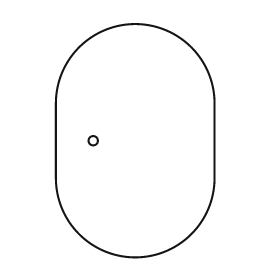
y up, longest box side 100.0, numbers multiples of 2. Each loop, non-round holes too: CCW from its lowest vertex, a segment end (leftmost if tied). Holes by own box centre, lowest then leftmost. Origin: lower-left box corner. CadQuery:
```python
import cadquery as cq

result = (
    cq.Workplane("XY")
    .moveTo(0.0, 34.0)
    .threePointArc((34.0, 0.0), (68.0, 34.0))
    .lineTo(68.0, 66.0)
    .threePointArc((34.0, 100.0), (0.0, 66.0))
    .close()
    .moveTo(16.0, 50.0)
    .circle(2.0)
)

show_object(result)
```